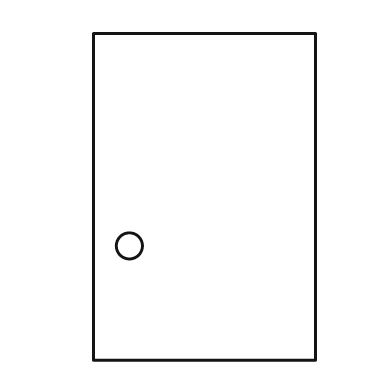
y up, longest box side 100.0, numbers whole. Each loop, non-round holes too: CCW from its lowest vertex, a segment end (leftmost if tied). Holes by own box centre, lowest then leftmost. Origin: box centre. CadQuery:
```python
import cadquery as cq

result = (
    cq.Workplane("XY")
    .moveTo(-34.0, -50.0)
    .lineTo(34.0, -50.0)
    .lineTo(34.0, 50.0)
    .lineTo(-34.0, 50.0)
    .close()
    .moveTo(-23.0, -15.0)
    .circle(4.0)
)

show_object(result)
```